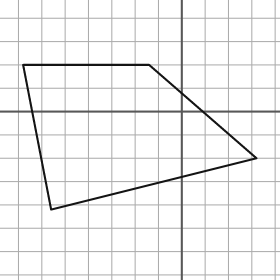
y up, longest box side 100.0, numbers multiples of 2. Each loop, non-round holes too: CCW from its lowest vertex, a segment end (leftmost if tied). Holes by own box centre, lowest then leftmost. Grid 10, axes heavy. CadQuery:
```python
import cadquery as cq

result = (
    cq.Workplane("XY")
    .moveTo(-56.0, -42.0)
    .lineTo(32.0, -20.0)
    .lineTo(-14.0, 20.0)
    .lineTo(-68.0, 20.0)
    .close()
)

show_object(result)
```